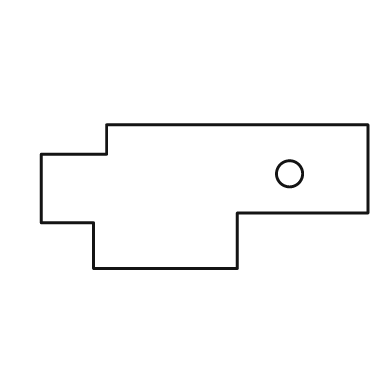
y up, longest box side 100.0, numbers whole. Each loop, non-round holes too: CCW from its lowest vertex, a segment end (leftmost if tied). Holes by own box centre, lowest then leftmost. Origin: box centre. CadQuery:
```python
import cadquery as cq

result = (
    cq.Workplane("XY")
    .moveTo(-34.0, -22.0)
    .lineTo(10.0, -22.0)
    .lineTo(10.0, -5.0)
    .lineTo(50.0, -5.0)
    .lineTo(50.0, 22.0)
    .lineTo(-30.0, 22.0)
    .lineTo(-30.0, 13.0)
    .lineTo(-50.0, 13.0)
    .lineTo(-50.0, -8.0)
    .lineTo(-34.0, -8.0)
    .close()
    .moveTo(26.0, 7.0)
    .circle(4.0)
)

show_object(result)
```